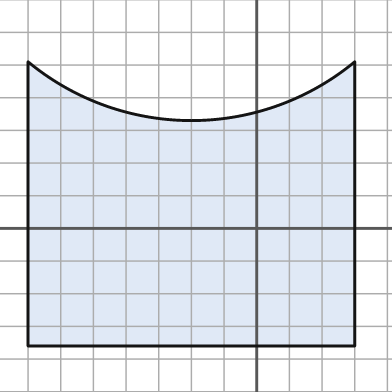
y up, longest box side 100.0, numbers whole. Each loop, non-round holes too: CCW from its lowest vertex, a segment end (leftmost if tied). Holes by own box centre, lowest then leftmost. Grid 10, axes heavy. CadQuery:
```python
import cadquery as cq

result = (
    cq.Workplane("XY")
    .moveTo(-70.0, -36.0)
    .lineTo(30.0, -36.0)
    .lineTo(30.0, 51.0)
    .threePointArc((-20.0, 33.0), (-70.0, 51.0))
    .close()
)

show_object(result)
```